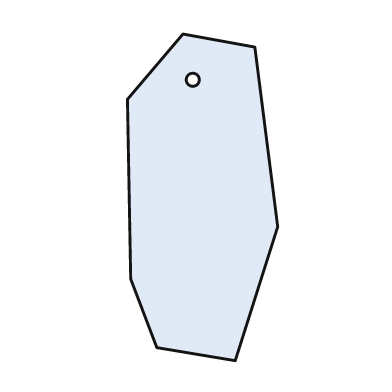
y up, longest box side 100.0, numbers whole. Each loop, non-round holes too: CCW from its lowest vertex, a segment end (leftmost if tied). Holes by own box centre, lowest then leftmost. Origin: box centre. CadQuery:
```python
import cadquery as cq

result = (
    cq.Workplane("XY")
    .moveTo(10.0, -50.0)
    .lineTo(23.0, -9.0)
    .lineTo(16.0, 46.0)
    .lineTo(-6.0, 50.0)
    .lineTo(-23.0, 30.0)
    .lineTo(-22.0, -25.0)
    .lineTo(-14.0, -46.0)
    .close()
    .moveTo(-3.0, 36.0)
    .circle(2.0)
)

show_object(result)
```